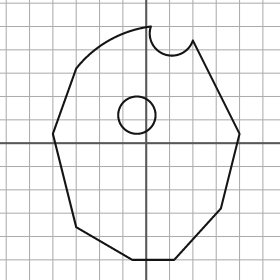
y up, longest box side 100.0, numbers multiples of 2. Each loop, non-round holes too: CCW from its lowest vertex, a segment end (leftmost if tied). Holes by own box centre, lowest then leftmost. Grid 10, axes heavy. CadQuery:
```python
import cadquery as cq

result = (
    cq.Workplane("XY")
    .moveTo(-6.0, -50.0)
    .lineTo(12.0, -50.0)
    .lineTo(32.0, -28.0)
    .lineTo(40.0, 4.0)
    .lineTo(20.0, 44.0)
    .threePointArc((8.0, 38.0), (2.0, 50.0))
    .threePointArc((-16.0, 44.0), (-30.0, 32.0))
    .lineTo(-40.0, 4.0)
    .lineTo(-30.0, -36.0)
    .close()
    .moveTo(-4.0, 12.0)
    .circle(8.0)
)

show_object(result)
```